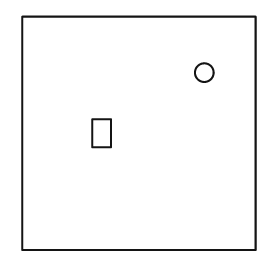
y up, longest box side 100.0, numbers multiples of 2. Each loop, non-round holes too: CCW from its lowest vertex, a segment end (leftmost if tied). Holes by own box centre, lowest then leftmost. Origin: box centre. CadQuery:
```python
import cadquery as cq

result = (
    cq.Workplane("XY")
    .moveTo(-50.0, -50.0)
    .lineTo(50.0, -50.0)
    .lineTo(50.0, 50.0)
    .lineTo(-50.0, 50.0)
    .close()
    .moveTo(-20.0, -6.0)
    .lineTo(-12.0, -6.0)
    .lineTo(-12.0, 6.0)
    .lineTo(-20.0, 6.0)
    .close()
    .moveTo(28.0, 26.0)
    .circle(4.0)
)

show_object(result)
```